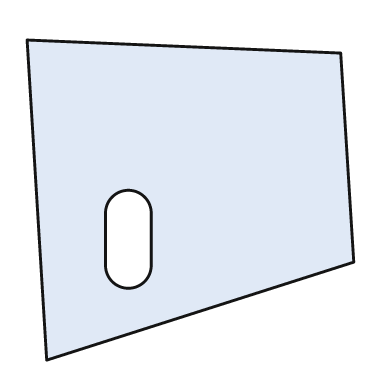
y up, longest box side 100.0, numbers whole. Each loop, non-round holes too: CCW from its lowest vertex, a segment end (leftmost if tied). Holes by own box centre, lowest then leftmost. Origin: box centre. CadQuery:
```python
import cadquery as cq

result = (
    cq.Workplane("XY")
    .moveTo(-44.0, -49.0)
    .lineTo(50.0, -19.0)
    .lineTo(46.0, 45.0)
    .lineTo(-50.0, 49.0)
    .close()
    .moveTo(-26.0, -20.0)
    .threePointArc((-19.0, -27.0), (-12.0, -20.0))
    .lineTo(-12.0, -4.0)
    .threePointArc((-19.0, 3.0), (-26.0, -4.0))
    .close()
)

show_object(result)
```